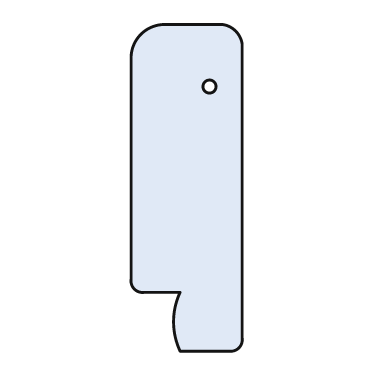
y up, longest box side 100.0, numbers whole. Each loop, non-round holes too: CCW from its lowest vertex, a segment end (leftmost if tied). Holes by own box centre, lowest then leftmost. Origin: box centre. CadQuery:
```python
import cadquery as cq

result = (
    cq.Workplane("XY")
    .moveTo(-2.0, -50.0)
    .lineTo(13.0, -50.0)
    .threePointArc((16.0, -49.0), (17.0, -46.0))
    .lineTo(17.0, 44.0)
    .threePointArc((15.0, 48.0), (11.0, 50.0))
    .lineTo(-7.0, 50.0)
    .threePointArc((-14.0, 47.0), (-17.0, 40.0))
    .lineTo(-17.0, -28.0)
    .threePointArc((-16.0, -31.0), (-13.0, -32.0))
    .lineTo(-2.0, -32.0)
    .threePointArc((-4.0, -41.0), (-2.0, -50.0))
    .close()
    .moveTo(7.0, 31.0)
    .circle(2.0)
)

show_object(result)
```